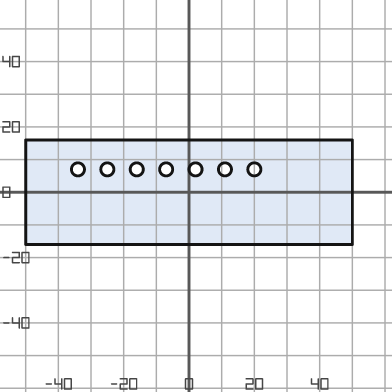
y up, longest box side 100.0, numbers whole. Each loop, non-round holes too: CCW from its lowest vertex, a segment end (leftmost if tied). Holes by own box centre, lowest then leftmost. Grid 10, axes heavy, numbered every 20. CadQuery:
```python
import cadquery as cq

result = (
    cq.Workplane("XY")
    .moveTo(-50.0, -16.0)
    .lineTo(50.0, -16.0)
    .lineTo(50.0, 16.0)
    .lineTo(-50.0, 16.0)
    .close()
    .moveTo(-34.0, 7.0)
    .circle(2.0)
    .moveTo(-25.0, 7.0)
    .circle(2.0)
    .moveTo(-16.0, 7.0)
    .circle(2.0)
    .moveTo(-7.0, 7.0)
    .circle(2.0)
    .moveTo(2.0, 7.0)
    .circle(2.0)
    .moveTo(11.0, 7.0)
    .circle(2.0)
    .moveTo(20.0, 7.0)
    .circle(2.0)
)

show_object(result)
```